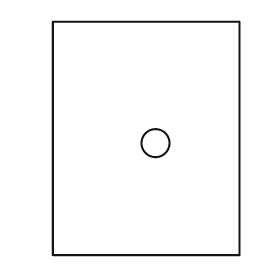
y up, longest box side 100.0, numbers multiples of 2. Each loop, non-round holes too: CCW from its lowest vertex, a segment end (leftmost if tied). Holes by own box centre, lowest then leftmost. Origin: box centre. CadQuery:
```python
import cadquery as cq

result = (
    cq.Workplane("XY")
    .moveTo(-40.0, -50.0)
    .lineTo(40.0, -50.0)
    .lineTo(40.0, 50.0)
    .lineTo(-40.0, 50.0)
    .close()
    .moveTo(4.0, -2.0)
    .circle(6.0)
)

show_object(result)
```